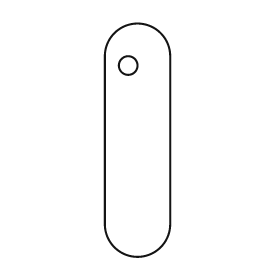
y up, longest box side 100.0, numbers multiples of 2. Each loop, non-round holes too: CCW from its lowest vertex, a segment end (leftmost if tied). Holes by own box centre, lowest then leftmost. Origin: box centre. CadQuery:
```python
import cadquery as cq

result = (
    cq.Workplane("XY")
    .moveTo(-14.0, -36.0)
    .threePointArc((0.0, -50.0), (14.0, -36.0))
    .lineTo(14.0, 36.0)
    .threePointArc((0.0, 50.0), (-14.0, 36.0))
    .close()
    .moveTo(-4.0, 32.0)
    .circle(4.0)
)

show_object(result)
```